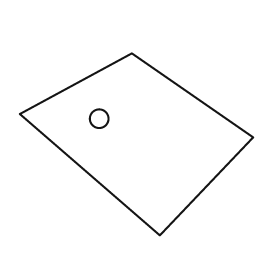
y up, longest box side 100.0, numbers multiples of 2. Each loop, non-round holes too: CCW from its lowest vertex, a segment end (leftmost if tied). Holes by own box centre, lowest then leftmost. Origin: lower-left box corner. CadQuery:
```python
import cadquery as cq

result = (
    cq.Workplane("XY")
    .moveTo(60.0, 0.0)
    .lineTo(100.0, 42.0)
    .lineTo(48.0, 78.0)
    .lineTo(0.0, 52.0)
    .close()
    .moveTo(34.0, 50.0)
    .circle(4.0)
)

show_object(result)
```